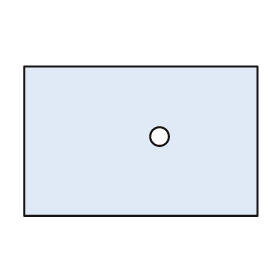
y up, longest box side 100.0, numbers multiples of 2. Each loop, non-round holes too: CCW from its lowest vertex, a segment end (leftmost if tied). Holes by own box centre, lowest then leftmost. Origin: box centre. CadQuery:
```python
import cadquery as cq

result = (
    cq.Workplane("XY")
    .moveTo(-50.0, -32.0)
    .lineTo(50.0, -32.0)
    .lineTo(50.0, 32.0)
    .lineTo(-50.0, 32.0)
    .close()
    .moveTo(8.0, 2.0)
    .circle(4.0)
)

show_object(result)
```